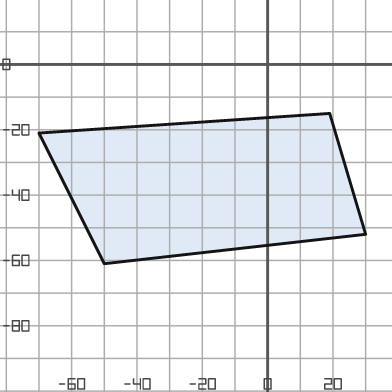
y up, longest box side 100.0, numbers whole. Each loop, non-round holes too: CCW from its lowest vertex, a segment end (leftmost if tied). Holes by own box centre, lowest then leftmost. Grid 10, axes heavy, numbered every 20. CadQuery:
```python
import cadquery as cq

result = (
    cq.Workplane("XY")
    .moveTo(-50.0, -61.0)
    .lineTo(30.0, -52.0)
    .lineTo(19.0, -15.0)
    .lineTo(-70.0, -21.0)
    .close()
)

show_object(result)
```